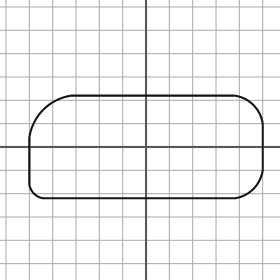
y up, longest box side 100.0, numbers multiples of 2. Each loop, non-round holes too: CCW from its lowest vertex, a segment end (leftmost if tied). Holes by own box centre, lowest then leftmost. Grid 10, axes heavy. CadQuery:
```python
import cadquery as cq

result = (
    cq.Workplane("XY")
    .moveTo(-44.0, -22.0)
    .lineTo(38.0, -22.0)
    .threePointArc((46.0, -18.0), (50.0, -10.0))
    .lineTo(50.0, 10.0)
    .threePointArc((46.0, 18.0), (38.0, 22.0))
    .lineTo(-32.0, 22.0)
    .threePointArc((-44.0, 16.0), (-50.0, 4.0))
    .lineTo(-50.0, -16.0)
    .threePointArc((-48.0, -20.0), (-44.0, -22.0))
    .close()
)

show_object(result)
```